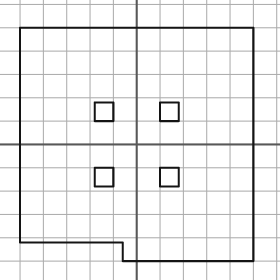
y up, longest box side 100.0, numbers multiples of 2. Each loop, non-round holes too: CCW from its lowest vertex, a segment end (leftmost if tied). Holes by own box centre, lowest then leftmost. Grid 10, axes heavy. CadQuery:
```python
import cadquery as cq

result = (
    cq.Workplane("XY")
    .moveTo(-6.0, -50.0)
    .lineTo(50.0, -50.0)
    .lineTo(50.0, 50.0)
    .lineTo(-50.0, 50.0)
    .lineTo(-50.0, -42.0)
    .lineTo(-6.0, -42.0)
    .close()
    .moveTo(-18.0, -18.0)
    .lineTo(-10.0, -18.0)
    .lineTo(-10.0, -10.0)
    .lineTo(-18.0, -10.0)
    .close()
    .moveTo(10.0, -18.0)
    .lineTo(18.0, -18.0)
    .lineTo(18.0, -10.0)
    .lineTo(10.0, -10.0)
    .close()
    .moveTo(-18.0, 10.0)
    .lineTo(-10.0, 10.0)
    .lineTo(-10.0, 18.0)
    .lineTo(-18.0, 18.0)
    .close()
    .moveTo(10.0, 10.0)
    .lineTo(18.0, 10.0)
    .lineTo(18.0, 18.0)
    .lineTo(10.0, 18.0)
    .close()
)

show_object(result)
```